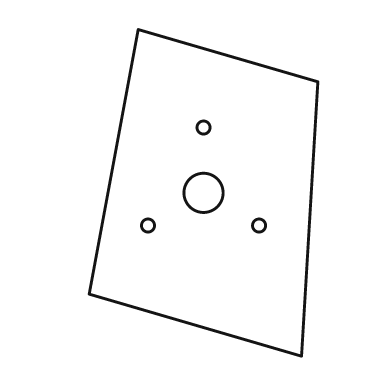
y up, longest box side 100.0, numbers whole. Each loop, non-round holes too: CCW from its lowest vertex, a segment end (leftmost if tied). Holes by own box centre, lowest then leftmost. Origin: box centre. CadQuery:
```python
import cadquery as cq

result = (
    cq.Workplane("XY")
    .moveTo(30.0, -50.0)
    .lineTo(35.0, 34.0)
    .lineTo(-20.0, 50.0)
    .lineTo(-35.0, -31.0)
    .close()
    .moveTo(-17.0, -10.0)
    .circle(2.0)
    .moveTo(17.0, -10.0)
    .circle(2.0)
    .moveTo(0.0, 0.0)
    .circle(6.0)
    .moveTo(0.0, 20.0)
    .circle(2.0)
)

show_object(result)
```